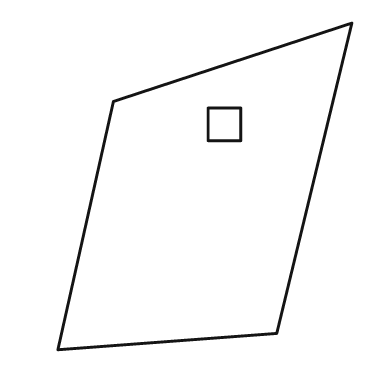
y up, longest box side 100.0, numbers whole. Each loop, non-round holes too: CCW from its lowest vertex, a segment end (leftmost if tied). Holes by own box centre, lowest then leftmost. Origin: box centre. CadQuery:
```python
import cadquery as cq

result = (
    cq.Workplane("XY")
    .moveTo(-45.0, -50.0)
    .lineTo(22.0, -45.0)
    .lineTo(45.0, 50.0)
    .lineTo(-28.0, 26.0)
    .close()
    .moveTo(1.0, 14.0)
    .lineTo(11.0, 14.0)
    .lineTo(11.0, 24.0)
    .lineTo(1.0, 24.0)
    .close()
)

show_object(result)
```